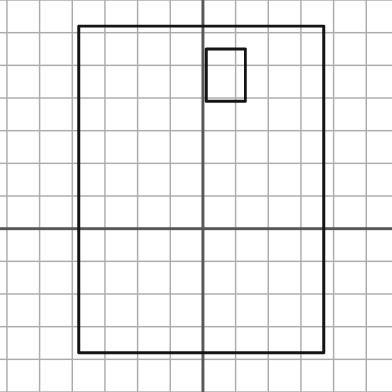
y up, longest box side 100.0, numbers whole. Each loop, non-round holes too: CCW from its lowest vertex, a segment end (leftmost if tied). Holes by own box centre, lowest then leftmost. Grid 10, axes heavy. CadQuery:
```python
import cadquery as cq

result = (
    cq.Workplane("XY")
    .moveTo(-38.0, -38.0)
    .lineTo(37.0, -38.0)
    .lineTo(37.0, 62.0)
    .lineTo(-38.0, 62.0)
    .close()
    .moveTo(1.0, 39.0)
    .lineTo(13.0, 39.0)
    .lineTo(13.0, 55.0)
    .lineTo(1.0, 55.0)
    .close()
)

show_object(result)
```